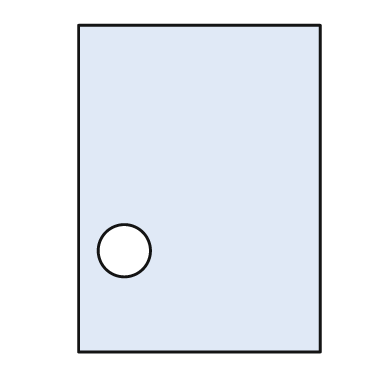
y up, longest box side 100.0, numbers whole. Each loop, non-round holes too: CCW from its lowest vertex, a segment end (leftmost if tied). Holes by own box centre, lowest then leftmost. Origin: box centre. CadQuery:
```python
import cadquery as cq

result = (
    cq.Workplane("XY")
    .moveTo(-37.0, -50.0)
    .lineTo(37.0, -50.0)
    .lineTo(37.0, 50.0)
    .lineTo(-37.0, 50.0)
    .close()
    .moveTo(-23.0, -19.0)
    .circle(8.0)
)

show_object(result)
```